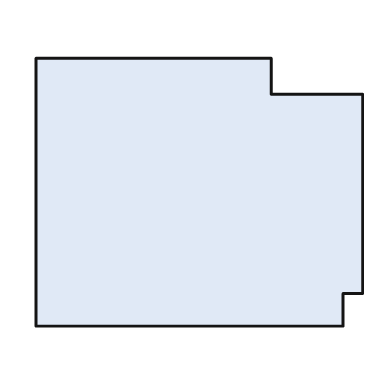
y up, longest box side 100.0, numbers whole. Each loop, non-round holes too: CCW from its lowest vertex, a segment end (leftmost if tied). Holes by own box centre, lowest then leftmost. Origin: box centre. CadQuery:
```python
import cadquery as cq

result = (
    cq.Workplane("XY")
    .moveTo(-50.0, -41.0)
    .lineTo(44.0, -41.0)
    .lineTo(44.0, -31.0)
    .lineTo(50.0, -31.0)
    .lineTo(50.0, 30.0)
    .lineTo(22.0, 30.0)
    .lineTo(22.0, 41.0)
    .lineTo(-50.0, 41.0)
    .close()
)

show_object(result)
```